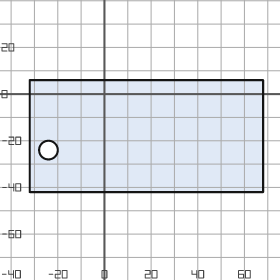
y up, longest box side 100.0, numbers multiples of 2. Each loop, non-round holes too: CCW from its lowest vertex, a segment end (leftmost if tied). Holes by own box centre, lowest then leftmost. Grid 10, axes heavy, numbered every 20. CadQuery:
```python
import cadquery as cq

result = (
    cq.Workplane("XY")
    .moveTo(-32.0, -42.0)
    .lineTo(68.0, -42.0)
    .lineTo(68.0, 6.0)
    .lineTo(-32.0, 6.0)
    .close()
    .moveTo(-24.0, -24.0)
    .circle(4.0)
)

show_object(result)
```